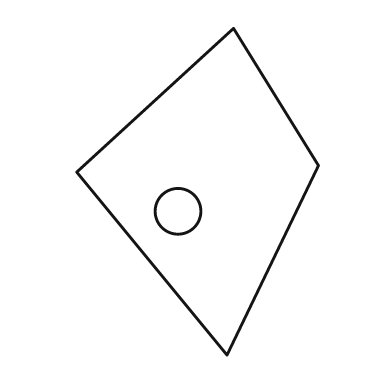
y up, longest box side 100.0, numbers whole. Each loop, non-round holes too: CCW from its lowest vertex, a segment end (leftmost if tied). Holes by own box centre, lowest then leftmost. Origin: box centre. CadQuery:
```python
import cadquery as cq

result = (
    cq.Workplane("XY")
    .moveTo(9.0, -50.0)
    .lineTo(37.0, 8.0)
    .lineTo(11.0, 50.0)
    .lineTo(-37.0, 6.0)
    .close()
    .moveTo(-6.0, -6.0)
    .circle(7.0)
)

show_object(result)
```